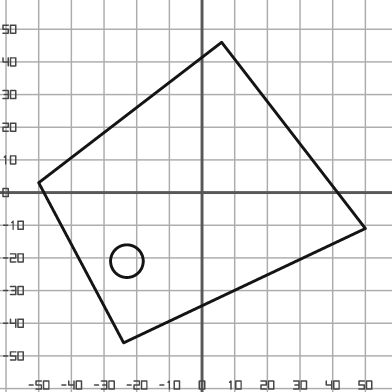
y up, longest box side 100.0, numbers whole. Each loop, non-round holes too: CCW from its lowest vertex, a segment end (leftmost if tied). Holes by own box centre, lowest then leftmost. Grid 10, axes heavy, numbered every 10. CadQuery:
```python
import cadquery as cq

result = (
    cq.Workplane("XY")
    .moveTo(-24.0, -46.0)
    .lineTo(50.0, -11.0)
    .lineTo(6.0, 46.0)
    .lineTo(-50.0, 3.0)
    .close()
    .moveTo(-23.0, -21.0)
    .circle(5.0)
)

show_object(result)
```